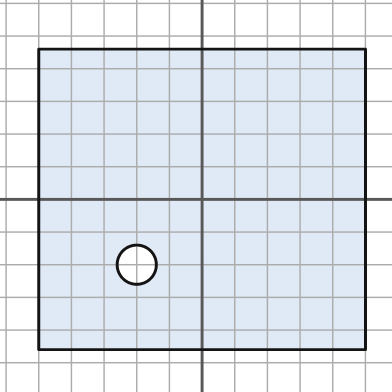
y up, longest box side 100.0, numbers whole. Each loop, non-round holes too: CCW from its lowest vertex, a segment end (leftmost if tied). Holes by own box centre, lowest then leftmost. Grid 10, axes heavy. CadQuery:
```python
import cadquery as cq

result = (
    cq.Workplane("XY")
    .moveTo(-50.0, -46.0)
    .lineTo(50.0, -46.0)
    .lineTo(50.0, 46.0)
    .lineTo(-50.0, 46.0)
    .close()
    .moveTo(-20.0, -20.0)
    .circle(6.0)
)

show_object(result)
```